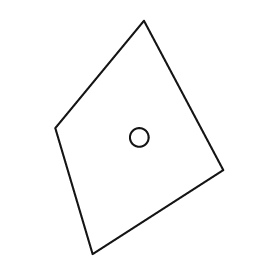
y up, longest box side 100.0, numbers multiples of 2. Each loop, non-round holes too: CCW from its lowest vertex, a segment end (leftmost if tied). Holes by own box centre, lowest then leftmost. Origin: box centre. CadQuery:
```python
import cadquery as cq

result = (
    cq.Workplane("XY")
    .moveTo(-20.0, -50.0)
    .lineTo(36.0, -14.0)
    .lineTo(2.0, 50.0)
    .lineTo(-36.0, 4.0)
    .close()
    .moveTo(0.0, 0.0)
    .circle(4.0)
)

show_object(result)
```